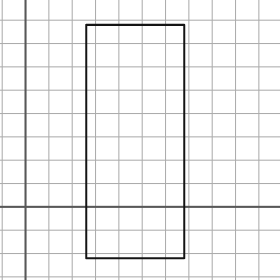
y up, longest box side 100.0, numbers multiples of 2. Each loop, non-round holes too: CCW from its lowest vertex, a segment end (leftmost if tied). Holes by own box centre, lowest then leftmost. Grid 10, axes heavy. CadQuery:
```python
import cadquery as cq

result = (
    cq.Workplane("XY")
    .moveTo(26.0, -22.0)
    .lineTo(68.0, -22.0)
    .lineTo(68.0, 78.0)
    .lineTo(26.0, 78.0)
    .close()
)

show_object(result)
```